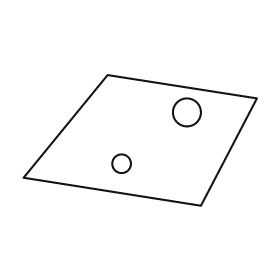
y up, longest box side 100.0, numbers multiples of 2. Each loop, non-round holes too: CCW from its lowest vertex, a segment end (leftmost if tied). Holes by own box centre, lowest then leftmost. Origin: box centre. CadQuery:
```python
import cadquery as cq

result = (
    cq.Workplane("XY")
    .moveTo(26.0, -28.0)
    .lineTo(50.0, 18.0)
    .lineTo(-14.0, 28.0)
    .lineTo(-50.0, -16.0)
    .close()
    .moveTo(-8.0, -10.0)
    .circle(4.0)
    .moveTo(20.0, 12.0)
    .circle(6.0)
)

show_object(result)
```